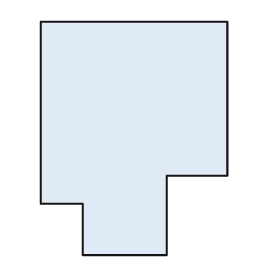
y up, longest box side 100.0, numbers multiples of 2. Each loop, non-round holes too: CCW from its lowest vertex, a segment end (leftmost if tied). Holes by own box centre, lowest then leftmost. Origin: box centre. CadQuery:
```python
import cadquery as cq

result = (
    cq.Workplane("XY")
    .moveTo(-22.0, -50.0)
    .lineTo(14.0, -50.0)
    .lineTo(14.0, -16.0)
    .lineTo(40.0, -16.0)
    .lineTo(40.0, 50.0)
    .lineTo(-40.0, 50.0)
    .lineTo(-40.0, -28.0)
    .lineTo(-22.0, -28.0)
    .close()
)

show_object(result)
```